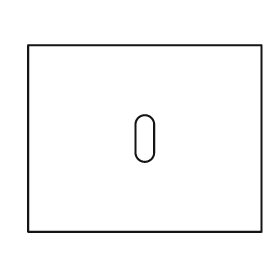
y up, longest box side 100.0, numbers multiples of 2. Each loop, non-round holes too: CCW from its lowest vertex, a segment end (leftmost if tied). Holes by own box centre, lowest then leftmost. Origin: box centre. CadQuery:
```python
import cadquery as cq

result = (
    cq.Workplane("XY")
    .moveTo(-50.0, -40.0)
    .lineTo(50.0, -40.0)
    .lineTo(50.0, 40.0)
    .lineTo(-50.0, 40.0)
    .close()
    .moveTo(-4.0, -6.0)
    .threePointArc((0.0, -10.0), (4.0, -6.0))
    .lineTo(4.0, 6.0)
    .threePointArc((0.0, 10.0), (-4.0, 6.0))
    .close()
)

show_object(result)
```